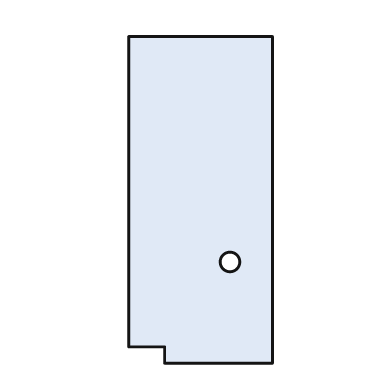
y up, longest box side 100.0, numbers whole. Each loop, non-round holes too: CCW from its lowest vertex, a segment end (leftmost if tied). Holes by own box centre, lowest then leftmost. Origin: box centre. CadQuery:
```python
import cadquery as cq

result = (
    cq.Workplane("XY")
    .moveTo(-11.0, -50.0)
    .lineTo(22.0, -50.0)
    .lineTo(22.0, 50.0)
    .lineTo(-22.0, 50.0)
    .lineTo(-22.0, -45.0)
    .lineTo(-11.0, -45.0)
    .close()
    .moveTo(9.0, -19.0)
    .circle(3.0)
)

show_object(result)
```